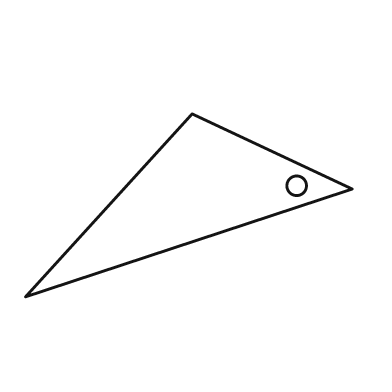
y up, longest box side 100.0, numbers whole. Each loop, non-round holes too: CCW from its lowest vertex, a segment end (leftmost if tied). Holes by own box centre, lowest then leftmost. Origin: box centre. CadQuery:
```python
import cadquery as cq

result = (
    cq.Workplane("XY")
    .moveTo(-50.0, -28.0)
    .lineTo(50.0, 5.0)
    .lineTo(1.0, 28.0)
    .close()
    .moveTo(33.0, 6.0)
    .circle(3.0)
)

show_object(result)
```